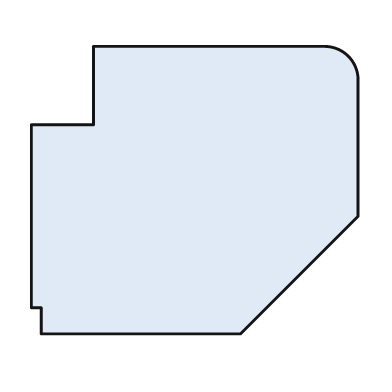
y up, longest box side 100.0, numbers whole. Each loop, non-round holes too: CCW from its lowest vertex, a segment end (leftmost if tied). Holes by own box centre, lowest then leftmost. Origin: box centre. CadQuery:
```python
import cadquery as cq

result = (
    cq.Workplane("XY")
    .moveTo(-47.0, -44.0)
    .lineTo(14.0, -44.0)
    .lineTo(50.0, -8.0)
    .lineTo(50.0, 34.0)
    .threePointArc((47.0, 41.0), (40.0, 44.0))
    .lineTo(-31.0, 44.0)
    .lineTo(-31.0, 20.0)
    .lineTo(-50.0, 20.0)
    .lineTo(-50.0, -36.0)
    .lineTo(-47.0, -36.0)
    .close()
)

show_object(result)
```